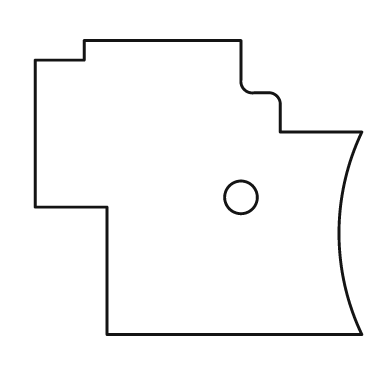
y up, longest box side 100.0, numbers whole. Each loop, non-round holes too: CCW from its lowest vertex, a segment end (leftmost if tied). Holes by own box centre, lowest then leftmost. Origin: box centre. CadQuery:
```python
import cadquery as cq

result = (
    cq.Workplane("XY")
    .moveTo(-28.0, -45.0)
    .lineTo(50.0, -45.0)
    .threePointArc((43.0, -14.0), (50.0, 17.0))
    .lineTo(25.0, 17.0)
    .lineTo(25.0, 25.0)
    .threePointArc((24.0, 28.0), (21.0, 29.0))
    .lineTo(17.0, 29.0)
    .threePointArc((14.0, 30.0), (13.0, 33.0))
    .lineTo(13.0, 45.0)
    .lineTo(-35.0, 45.0)
    .lineTo(-35.0, 39.0)
    .lineTo(-50.0, 39.0)
    .lineTo(-50.0, -6.0)
    .lineTo(-28.0, -6.0)
    .close()
    .moveTo(13.0, -3.0)
    .circle(5.0)
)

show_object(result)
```